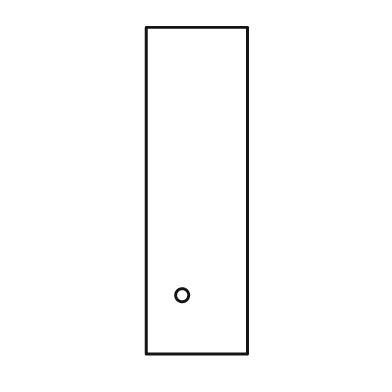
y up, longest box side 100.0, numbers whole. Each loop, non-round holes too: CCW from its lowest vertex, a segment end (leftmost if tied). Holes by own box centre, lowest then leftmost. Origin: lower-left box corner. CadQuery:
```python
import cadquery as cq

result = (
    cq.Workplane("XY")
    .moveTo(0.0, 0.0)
    .lineTo(31.0, 0.0)
    .lineTo(31.0, 100.0)
    .lineTo(0.0, 100.0)
    .close()
    .moveTo(11.0, 18.0)
    .circle(2.0)
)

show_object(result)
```